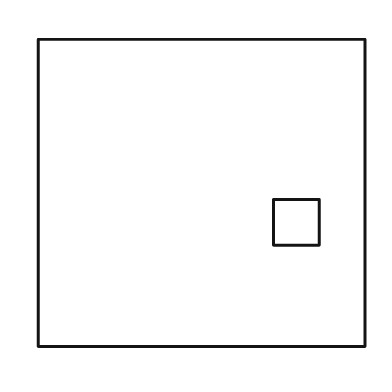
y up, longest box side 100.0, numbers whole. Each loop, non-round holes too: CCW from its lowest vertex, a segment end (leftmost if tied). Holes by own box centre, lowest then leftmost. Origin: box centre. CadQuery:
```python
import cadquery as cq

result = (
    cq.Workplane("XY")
    .moveTo(-50.0, -47.0)
    .lineTo(50.0, -47.0)
    .lineTo(50.0, 47.0)
    .lineTo(-50.0, 47.0)
    .close()
    .moveTo(22.0, -16.0)
    .lineTo(36.0, -16.0)
    .lineTo(36.0, -2.0)
    .lineTo(22.0, -2.0)
    .close()
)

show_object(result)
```